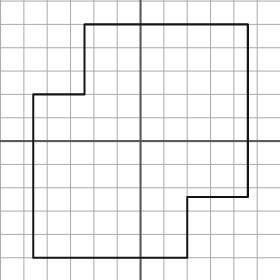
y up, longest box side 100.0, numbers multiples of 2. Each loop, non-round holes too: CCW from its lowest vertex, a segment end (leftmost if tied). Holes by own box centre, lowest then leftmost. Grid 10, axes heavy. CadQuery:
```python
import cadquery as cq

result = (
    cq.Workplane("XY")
    .moveTo(-46.0, -50.0)
    .lineTo(20.0, -50.0)
    .lineTo(20.0, -24.0)
    .lineTo(46.0, -24.0)
    .lineTo(46.0, 50.0)
    .lineTo(-24.0, 50.0)
    .lineTo(-24.0, 20.0)
    .lineTo(-46.0, 20.0)
    .close()
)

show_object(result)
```